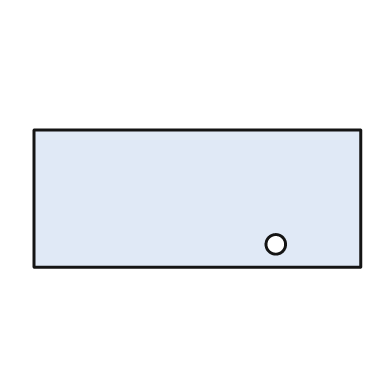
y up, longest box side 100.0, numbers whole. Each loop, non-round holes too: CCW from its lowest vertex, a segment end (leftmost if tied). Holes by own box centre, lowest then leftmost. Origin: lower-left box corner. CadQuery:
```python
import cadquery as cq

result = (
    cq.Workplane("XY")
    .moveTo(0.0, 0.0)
    .lineTo(100.0, 0.0)
    .lineTo(100.0, 42.0)
    .lineTo(0.0, 42.0)
    .close()
    .moveTo(74.0, 7.0)
    .circle(3.0)
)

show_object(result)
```